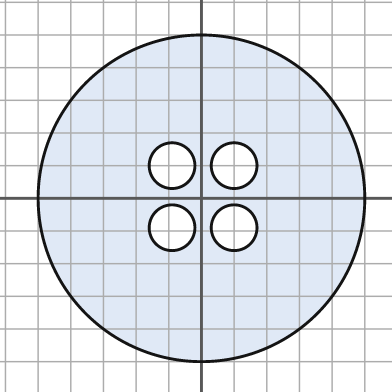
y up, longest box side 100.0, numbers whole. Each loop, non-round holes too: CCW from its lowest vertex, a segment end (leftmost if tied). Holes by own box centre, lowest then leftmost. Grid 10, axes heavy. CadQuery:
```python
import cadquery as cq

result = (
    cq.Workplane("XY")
    .moveTo(0.0, 0.0)
    .circle(50.0)
    .moveTo(-9.0, -9.0)
    .circle(7.0)
    .moveTo(10.0, -9.0)
    .circle(7.0)
    .moveTo(-9.0, 10.0)
    .circle(7.0)
    .moveTo(10.0, 10.0)
    .circle(7.0)
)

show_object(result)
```